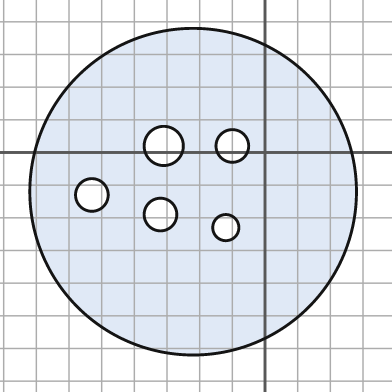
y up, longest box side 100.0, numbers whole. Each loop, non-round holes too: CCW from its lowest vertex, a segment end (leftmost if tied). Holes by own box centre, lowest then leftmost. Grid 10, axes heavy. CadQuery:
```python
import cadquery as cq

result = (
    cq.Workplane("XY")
    .moveTo(-22.0, -12.0)
    .circle(50.0)
    .moveTo(-12.0, -23.0)
    .circle(4.0)
    .moveTo(-32.0, -19.0)
    .circle(5.0)
    .moveTo(-53.0, -13.0)
    .circle(5.0)
    .moveTo(-31.0, 2.0)
    .circle(6.0)
    .moveTo(-10.0, 2.0)
    .circle(5.0)
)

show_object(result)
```